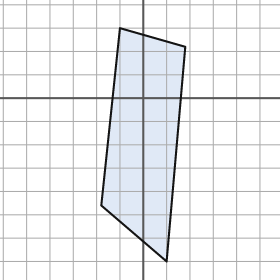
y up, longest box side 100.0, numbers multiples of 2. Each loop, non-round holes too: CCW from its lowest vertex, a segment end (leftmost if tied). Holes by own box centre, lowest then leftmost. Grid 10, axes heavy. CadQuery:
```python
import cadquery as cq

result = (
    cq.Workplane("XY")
    .moveTo(10.0, -70.0)
    .lineTo(18.0, 22.0)
    .lineTo(-10.0, 30.0)
    .lineTo(-18.0, -46.0)
    .close()
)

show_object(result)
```